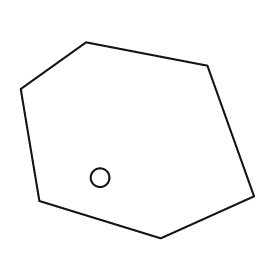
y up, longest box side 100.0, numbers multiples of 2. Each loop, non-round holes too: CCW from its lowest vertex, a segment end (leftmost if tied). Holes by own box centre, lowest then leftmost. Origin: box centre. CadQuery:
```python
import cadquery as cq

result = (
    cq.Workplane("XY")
    .moveTo(10.0, -42.0)
    .lineTo(50.0, -24.0)
    .lineTo(30.0, 32.0)
    .lineTo(-22.0, 42.0)
    .lineTo(-50.0, 22.0)
    .lineTo(-42.0, -26.0)
    .close()
    .moveTo(-16.0, -16.0)
    .circle(4.0)
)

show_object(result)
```